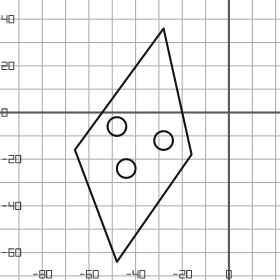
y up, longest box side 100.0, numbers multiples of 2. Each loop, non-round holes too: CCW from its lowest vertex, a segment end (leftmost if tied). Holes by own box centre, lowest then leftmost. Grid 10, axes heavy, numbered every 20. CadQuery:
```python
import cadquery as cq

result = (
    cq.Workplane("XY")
    .moveTo(-48.0, -64.0)
    .lineTo(-16.0, -18.0)
    .lineTo(-28.0, 36.0)
    .lineTo(-66.0, -16.0)
    .close()
    .moveTo(-44.0, -24.0)
    .circle(4.0)
    .moveTo(-28.0, -12.0)
    .circle(4.0)
    .moveTo(-48.0, -6.0)
    .circle(4.0)
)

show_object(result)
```